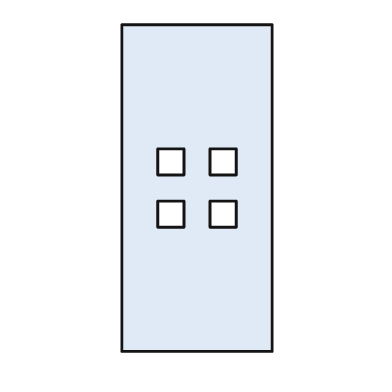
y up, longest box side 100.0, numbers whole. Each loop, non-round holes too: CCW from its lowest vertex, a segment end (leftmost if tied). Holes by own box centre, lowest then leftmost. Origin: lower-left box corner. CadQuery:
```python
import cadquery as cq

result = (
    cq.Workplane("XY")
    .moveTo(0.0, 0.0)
    .lineTo(46.0, 0.0)
    .lineTo(46.0, 100.0)
    .lineTo(0.0, 100.0)
    .close()
    .moveTo(11.0, 38.0)
    .lineTo(19.0, 38.0)
    .lineTo(19.0, 46.0)
    .lineTo(11.0, 46.0)
    .close()
    .moveTo(27.0, 38.0)
    .lineTo(35.0, 38.0)
    .lineTo(35.0, 46.0)
    .lineTo(27.0, 46.0)
    .close()
    .moveTo(11.0, 54.0)
    .lineTo(19.0, 54.0)
    .lineTo(19.0, 62.0)
    .lineTo(11.0, 62.0)
    .close()
    .moveTo(27.0, 54.0)
    .lineTo(35.0, 54.0)
    .lineTo(35.0, 62.0)
    .lineTo(27.0, 62.0)
    .close()
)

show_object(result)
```